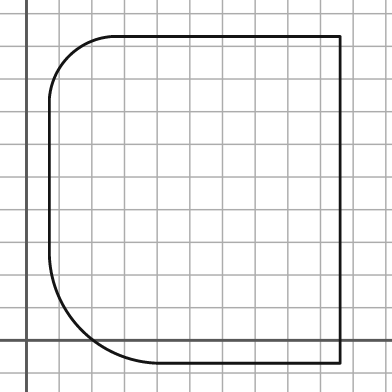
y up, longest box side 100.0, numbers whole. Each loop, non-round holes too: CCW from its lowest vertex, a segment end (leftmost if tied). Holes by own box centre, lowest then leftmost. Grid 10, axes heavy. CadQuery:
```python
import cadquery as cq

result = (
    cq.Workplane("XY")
    .moveTo(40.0, -7.0)
    .lineTo(96.0, -7.0)
    .lineTo(96.0, 93.0)
    .lineTo(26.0, 93.0)
    .threePointArc((13.0, 87.0), (7.0, 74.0))
    .lineTo(7.0, 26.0)
    .threePointArc((17.0, 3.0), (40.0, -7.0))
    .close()
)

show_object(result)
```